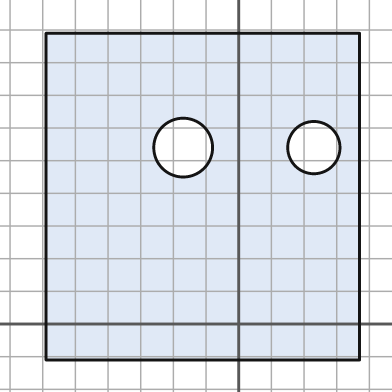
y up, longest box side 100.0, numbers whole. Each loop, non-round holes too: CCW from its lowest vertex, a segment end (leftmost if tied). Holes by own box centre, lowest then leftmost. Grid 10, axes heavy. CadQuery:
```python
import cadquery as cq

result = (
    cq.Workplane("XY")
    .moveTo(-59.0, -11.0)
    .lineTo(37.0, -11.0)
    .lineTo(37.0, 89.0)
    .lineTo(-59.0, 89.0)
    .close()
    .moveTo(-17.0, 54.0)
    .circle(9.0)
    .moveTo(23.0, 54.0)
    .circle(8.0)
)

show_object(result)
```